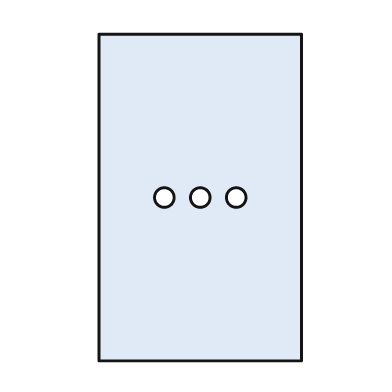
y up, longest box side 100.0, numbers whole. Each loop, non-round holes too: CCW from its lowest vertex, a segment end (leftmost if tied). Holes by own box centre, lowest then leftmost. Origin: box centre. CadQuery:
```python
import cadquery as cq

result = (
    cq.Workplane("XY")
    .moveTo(-31.0, -50.0)
    .lineTo(31.0, -50.0)
    .lineTo(31.0, 50.0)
    .lineTo(-31.0, 50.0)
    .close()
    .moveTo(-11.0, 0.0)
    .circle(3.0)
    .moveTo(0.0, 0.0)
    .circle(3.0)
    .moveTo(11.0, 0.0)
    .circle(3.0)
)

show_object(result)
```